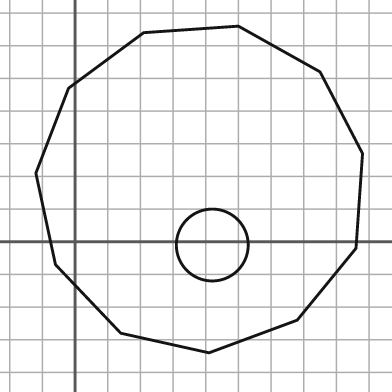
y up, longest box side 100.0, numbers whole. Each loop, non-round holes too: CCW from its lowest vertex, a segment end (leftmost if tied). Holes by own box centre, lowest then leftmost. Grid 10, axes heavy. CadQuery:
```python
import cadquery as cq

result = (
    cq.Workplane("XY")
    .moveTo(41.0, -34.0)
    .lineTo(68.0, -24.0)
    .lineTo(86.0, -2.0)
    .lineTo(88.0, 27.0)
    .lineTo(75.0, 52.0)
    .lineTo(50.0, 66.0)
    .lineTo(21.0, 64.0)
    .lineTo(-2.0, 47.0)
    .lineTo(-12.0, 21.0)
    .lineTo(-6.0, -7.0)
    .lineTo(14.0, -28.0)
    .close()
    .moveTo(42.0, -1.0)
    .circle(11.0)
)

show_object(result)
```